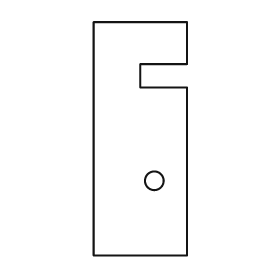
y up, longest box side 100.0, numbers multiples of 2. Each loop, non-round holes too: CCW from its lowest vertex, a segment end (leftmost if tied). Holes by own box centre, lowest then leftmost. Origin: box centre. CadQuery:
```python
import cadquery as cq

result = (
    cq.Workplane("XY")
    .moveTo(-20.0, -50.0)
    .lineTo(20.0, -50.0)
    .lineTo(20.0, 22.0)
    .lineTo(0.0, 22.0)
    .lineTo(0.0, 32.0)
    .lineTo(20.0, 32.0)
    .lineTo(20.0, 50.0)
    .lineTo(-20.0, 50.0)
    .close()
    .moveTo(6.0, -18.0)
    .circle(4.0)
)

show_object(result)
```